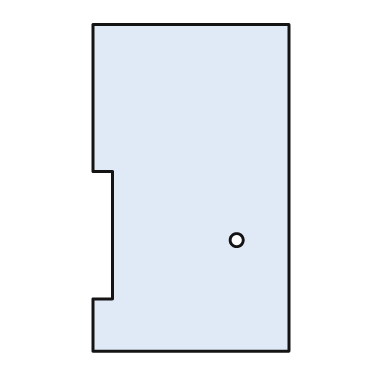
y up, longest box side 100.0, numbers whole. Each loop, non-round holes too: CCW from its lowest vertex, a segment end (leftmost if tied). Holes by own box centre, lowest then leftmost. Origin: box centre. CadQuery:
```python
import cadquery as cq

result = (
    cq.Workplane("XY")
    .moveTo(-30.0, -50.0)
    .lineTo(30.0, -50.0)
    .lineTo(30.0, 50.0)
    .lineTo(-30.0, 50.0)
    .lineTo(-30.0, 5.0)
    .lineTo(-24.0, 5.0)
    .lineTo(-24.0, -34.0)
    .lineTo(-30.0, -34.0)
    .close()
    .moveTo(14.0, -16.0)
    .circle(2.0)
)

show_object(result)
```